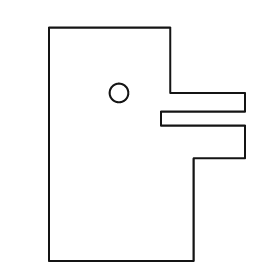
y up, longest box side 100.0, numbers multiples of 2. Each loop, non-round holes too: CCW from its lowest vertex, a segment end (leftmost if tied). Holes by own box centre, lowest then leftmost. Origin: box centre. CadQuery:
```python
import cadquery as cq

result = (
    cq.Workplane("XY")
    .moveTo(-42.0, -50.0)
    .lineTo(20.0, -50.0)
    .lineTo(20.0, -6.0)
    .lineTo(42.0, -6.0)
    .lineTo(42.0, 8.0)
    .lineTo(6.0, 8.0)
    .lineTo(6.0, 14.0)
    .lineTo(42.0, 14.0)
    .lineTo(42.0, 22.0)
    .lineTo(10.0, 22.0)
    .lineTo(10.0, 50.0)
    .lineTo(-42.0, 50.0)
    .close()
    .moveTo(-12.0, 22.0)
    .circle(4.0)
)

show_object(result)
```